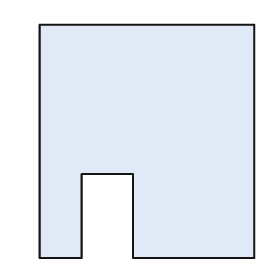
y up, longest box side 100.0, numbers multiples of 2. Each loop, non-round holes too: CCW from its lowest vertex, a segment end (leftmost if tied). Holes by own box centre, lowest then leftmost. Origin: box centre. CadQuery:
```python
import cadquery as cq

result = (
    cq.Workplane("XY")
    .moveTo(-46.0, -50.0)
    .lineTo(-28.0, -50.0)
    .lineTo(-28.0, -14.0)
    .lineTo(-6.0, -14.0)
    .lineTo(-6.0, -50.0)
    .lineTo(46.0, -50.0)
    .lineTo(46.0, 50.0)
    .lineTo(-46.0, 50.0)
    .close()
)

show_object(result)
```